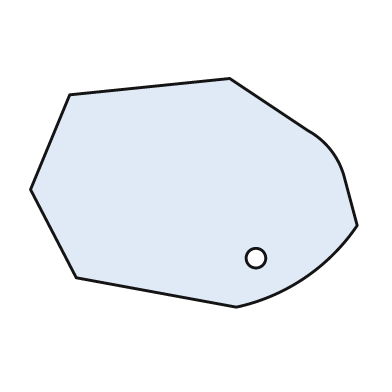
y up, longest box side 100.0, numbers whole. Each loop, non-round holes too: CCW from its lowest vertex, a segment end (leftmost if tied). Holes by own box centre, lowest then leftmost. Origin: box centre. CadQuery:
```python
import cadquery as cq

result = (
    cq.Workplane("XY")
    .moveTo(13.0, -35.0)
    .threePointArc((34.0, -26.0), (50.0, -10.0))
    .lineTo(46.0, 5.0)
    .threePointArc((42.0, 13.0), (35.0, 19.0))
    .lineTo(11.0, 35.0)
    .lineTo(-38.0, 30.0)
    .lineTo(-50.0, 1.0)
    .lineTo(-36.0, -26.0)
    .close()
    .moveTo(19.0, -20.0)
    .circle(3.0)
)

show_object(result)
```